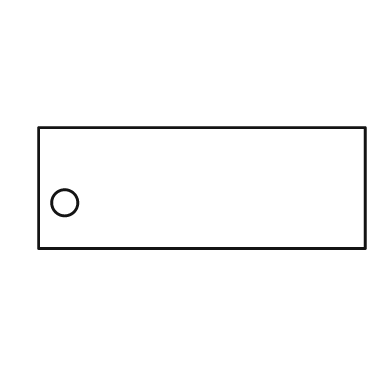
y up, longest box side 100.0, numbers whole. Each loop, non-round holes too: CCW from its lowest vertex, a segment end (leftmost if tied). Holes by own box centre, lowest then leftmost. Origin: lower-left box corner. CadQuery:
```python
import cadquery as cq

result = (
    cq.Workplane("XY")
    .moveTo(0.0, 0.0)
    .lineTo(100.0, 0.0)
    .lineTo(100.0, 37.0)
    .lineTo(0.0, 37.0)
    .close()
    .moveTo(8.0, 14.0)
    .circle(4.0)
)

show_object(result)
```